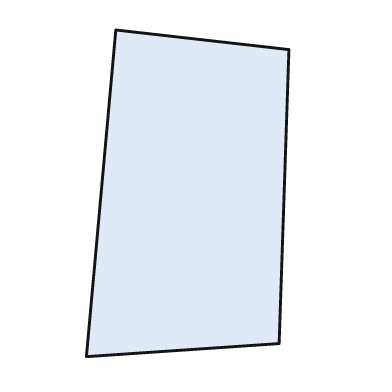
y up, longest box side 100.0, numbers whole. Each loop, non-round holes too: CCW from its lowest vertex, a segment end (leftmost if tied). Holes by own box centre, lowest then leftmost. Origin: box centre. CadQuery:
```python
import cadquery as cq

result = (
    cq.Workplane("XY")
    .moveTo(-31.0, -50.0)
    .lineTo(28.0, -46.0)
    .lineTo(31.0, 44.0)
    .lineTo(-22.0, 50.0)
    .close()
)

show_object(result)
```